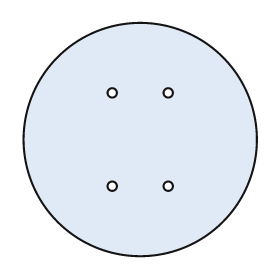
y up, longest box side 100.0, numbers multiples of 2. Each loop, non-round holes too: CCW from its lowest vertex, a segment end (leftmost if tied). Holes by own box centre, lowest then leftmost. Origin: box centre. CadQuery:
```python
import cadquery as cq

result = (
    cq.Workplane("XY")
    .moveTo(0.0, 0.0)
    .circle(50.0)
    .moveTo(-12.0, -20.0)
    .circle(2.0)
    .moveTo(12.0, -20.0)
    .circle(2.0)
    .moveTo(-12.0, 20.0)
    .circle(2.0)
    .moveTo(12.0, 20.0)
    .circle(2.0)
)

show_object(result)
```